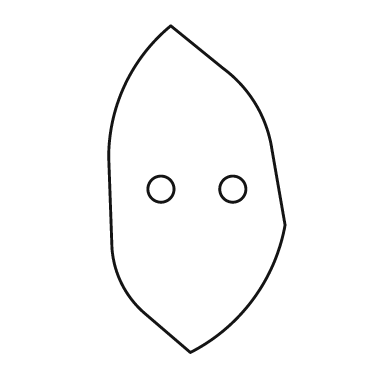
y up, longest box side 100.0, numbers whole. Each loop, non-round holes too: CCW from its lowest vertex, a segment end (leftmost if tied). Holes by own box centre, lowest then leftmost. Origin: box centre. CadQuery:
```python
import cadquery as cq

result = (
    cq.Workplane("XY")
    .moveTo(-2.0, -50.0)
    .threePointArc((17.0, -34.0), (27.0, -11.0))
    .lineTo(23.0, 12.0)
    .threePointArc((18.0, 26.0), (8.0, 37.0))
    .lineTo(-8.0, 50.0)
    .threePointArc((-22.0, 32.0), (-27.0, 10.0))
    .lineTo(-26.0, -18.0)
    .threePointArc((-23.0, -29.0), (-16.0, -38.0))
    .close()
    .moveTo(-11.0, 0.0)
    .circle(4.0)
    .moveTo(11.0, 0.0)
    .circle(4.0)
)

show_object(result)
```